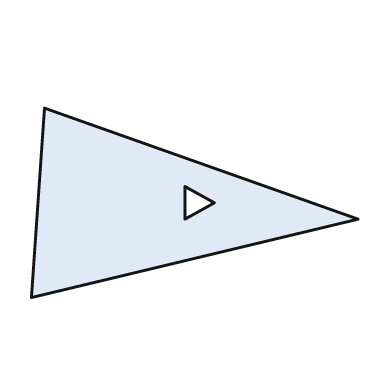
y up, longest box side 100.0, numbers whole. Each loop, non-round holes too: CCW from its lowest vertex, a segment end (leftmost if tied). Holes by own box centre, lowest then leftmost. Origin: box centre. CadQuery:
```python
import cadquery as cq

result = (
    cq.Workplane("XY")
    .moveTo(-50.0, -29.0)
    .lineTo(50.0, -5.0)
    .lineTo(-46.0, 29.0)
    .close()
    .moveTo(-3.0, -5.0)
    .lineTo(6.0, 0.0)
    .lineTo(-3.0, 5.0)
    .close()
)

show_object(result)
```